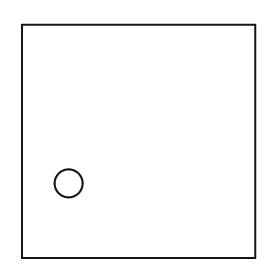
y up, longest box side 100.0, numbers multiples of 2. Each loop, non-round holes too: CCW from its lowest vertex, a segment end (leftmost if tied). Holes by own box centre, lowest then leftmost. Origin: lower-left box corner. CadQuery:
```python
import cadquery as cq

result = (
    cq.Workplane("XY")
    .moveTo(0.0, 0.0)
    .lineTo(100.0, 0.0)
    .lineTo(100.0, 100.0)
    .lineTo(0.0, 100.0)
    .close()
    .moveTo(20.0, 32.0)
    .circle(6.0)
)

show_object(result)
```